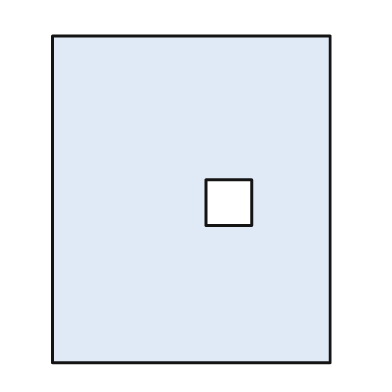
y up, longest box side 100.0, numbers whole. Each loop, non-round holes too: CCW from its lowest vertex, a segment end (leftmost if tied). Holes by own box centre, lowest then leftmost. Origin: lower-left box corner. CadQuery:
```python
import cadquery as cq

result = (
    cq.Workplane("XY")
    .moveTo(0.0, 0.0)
    .lineTo(85.0, 0.0)
    .lineTo(85.0, 100.0)
    .lineTo(0.0, 100.0)
    .close()
    .moveTo(47.0, 42.0)
    .lineTo(61.0, 42.0)
    .lineTo(61.0, 56.0)
    .lineTo(47.0, 56.0)
    .close()
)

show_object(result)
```